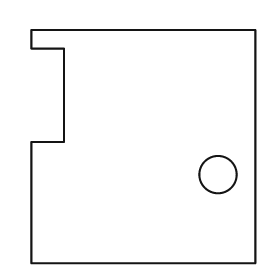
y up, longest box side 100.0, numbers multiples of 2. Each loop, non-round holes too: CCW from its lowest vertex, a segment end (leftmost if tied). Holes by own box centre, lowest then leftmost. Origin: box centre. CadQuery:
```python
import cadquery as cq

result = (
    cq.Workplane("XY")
    .moveTo(-48.0, -50.0)
    .lineTo(48.0, -50.0)
    .lineTo(48.0, 50.0)
    .lineTo(-48.0, 50.0)
    .lineTo(-48.0, 42.0)
    .lineTo(-34.0, 42.0)
    .lineTo(-34.0, 2.0)
    .lineTo(-48.0, 2.0)
    .close()
    .moveTo(32.0, -12.0)
    .circle(8.0)
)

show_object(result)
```